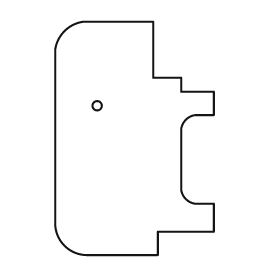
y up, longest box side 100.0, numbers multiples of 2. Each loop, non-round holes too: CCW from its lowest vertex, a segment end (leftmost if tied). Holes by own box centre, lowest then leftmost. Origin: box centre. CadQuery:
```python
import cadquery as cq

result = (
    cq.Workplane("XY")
    .moveTo(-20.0, -50.0)
    .lineTo(10.0, -50.0)
    .lineTo(10.0, -40.0)
    .lineTo(34.0, -40.0)
    .lineTo(34.0, -28.0)
    .lineTo(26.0, -28.0)
    .threePointArc((22.0, -26.0), (20.0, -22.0))
    .lineTo(20.0, 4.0)
    .threePointArc((22.0, 8.0), (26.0, 10.0))
    .lineTo(34.0, 10.0)
    .lineTo(34.0, 20.0)
    .lineTo(20.0, 20.0)
    .lineTo(20.0, 26.0)
    .lineTo(8.0, 26.0)
    .lineTo(8.0, 50.0)
    .lineTo(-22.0, 50.0)
    .threePointArc((-30.0, 46.0), (-34.0, 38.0))
    .lineTo(-34.0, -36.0)
    .threePointArc((-30.0, -46.0), (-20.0, -50.0))
    .close()
    .moveTo(-16.0, 14.0)
    .circle(2.0)
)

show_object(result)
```